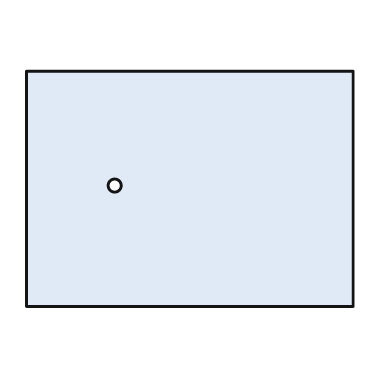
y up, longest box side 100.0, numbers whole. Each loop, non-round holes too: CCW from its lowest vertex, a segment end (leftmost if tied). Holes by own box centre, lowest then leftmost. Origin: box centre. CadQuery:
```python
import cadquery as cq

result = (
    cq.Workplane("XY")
    .moveTo(-50.0, -36.0)
    .lineTo(50.0, -36.0)
    .lineTo(50.0, 36.0)
    .lineTo(-50.0, 36.0)
    .close()
    .moveTo(-23.0, 1.0)
    .circle(2.0)
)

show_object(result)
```